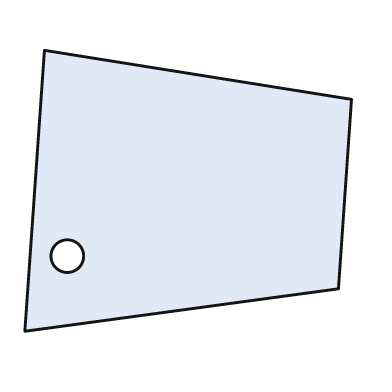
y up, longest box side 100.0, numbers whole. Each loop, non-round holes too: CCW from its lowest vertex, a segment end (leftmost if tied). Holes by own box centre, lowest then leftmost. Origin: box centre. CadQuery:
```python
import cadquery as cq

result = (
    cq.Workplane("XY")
    .moveTo(-50.0, -43.0)
    .lineTo(46.0, -30.0)
    .lineTo(50.0, 28.0)
    .lineTo(-44.0, 43.0)
    .close()
    .moveTo(-37.0, -20.0)
    .circle(5.0)
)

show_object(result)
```